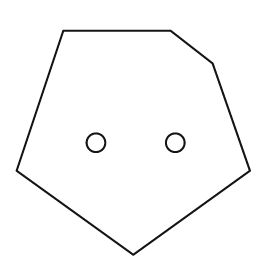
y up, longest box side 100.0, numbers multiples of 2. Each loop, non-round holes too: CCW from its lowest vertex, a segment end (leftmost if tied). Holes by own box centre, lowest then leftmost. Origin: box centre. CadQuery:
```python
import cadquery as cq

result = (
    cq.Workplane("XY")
    .moveTo(0.0, -48.0)
    .lineTo(50.0, -12.0)
    .lineTo(34.0, 34.0)
    .lineTo(16.0, 48.0)
    .lineTo(-30.0, 48.0)
    .lineTo(-50.0, -12.0)
    .close()
    .moveTo(-16.0, 0.0)
    .circle(4.0)
    .moveTo(18.0, 0.0)
    .circle(4.0)
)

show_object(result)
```